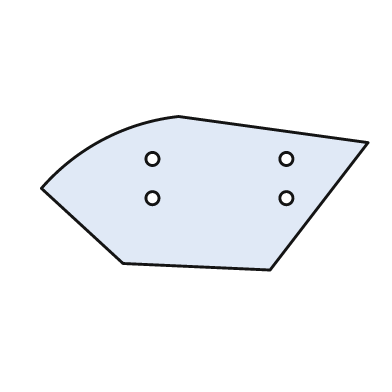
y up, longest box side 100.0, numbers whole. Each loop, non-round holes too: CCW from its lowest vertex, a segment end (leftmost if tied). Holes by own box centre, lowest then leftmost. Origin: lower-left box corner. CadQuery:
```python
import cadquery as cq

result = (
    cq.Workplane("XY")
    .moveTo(70.0, 0.0)
    .lineTo(100.0, 39.0)
    .lineTo(42.0, 47.0)
    .threePointArc((19.0, 40.0), (0.0, 25.0))
    .lineTo(25.0, 2.0)
    .close()
    .moveTo(34.0, 22.0)
    .circle(2.0)
    .moveTo(75.0, 22.0)
    .circle(2.0)
    .moveTo(34.0, 34.0)
    .circle(2.0)
    .moveTo(75.0, 34.0)
    .circle(2.0)
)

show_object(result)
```